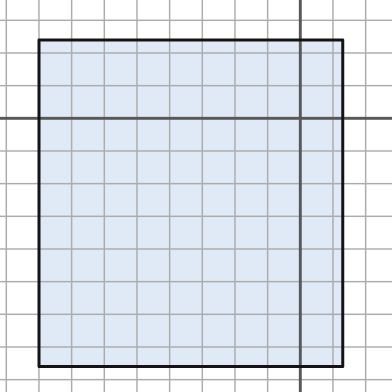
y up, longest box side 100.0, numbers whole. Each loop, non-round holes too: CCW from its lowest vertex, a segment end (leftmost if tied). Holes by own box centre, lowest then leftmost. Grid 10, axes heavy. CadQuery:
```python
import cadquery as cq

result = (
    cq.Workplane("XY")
    .moveTo(-80.0, -76.0)
    .lineTo(13.0, -76.0)
    .lineTo(13.0, 24.0)
    .lineTo(-80.0, 24.0)
    .close()
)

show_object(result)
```